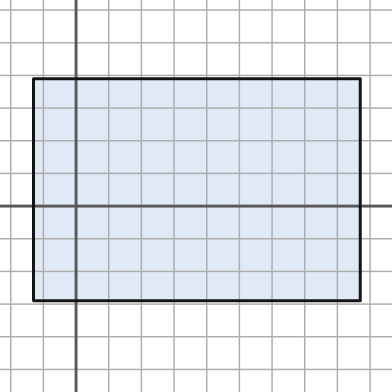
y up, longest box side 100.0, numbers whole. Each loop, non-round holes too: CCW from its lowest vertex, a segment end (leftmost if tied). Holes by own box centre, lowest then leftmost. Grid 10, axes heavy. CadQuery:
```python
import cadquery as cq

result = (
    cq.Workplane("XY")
    .moveTo(-13.0, -29.0)
    .lineTo(87.0, -29.0)
    .lineTo(87.0, 39.0)
    .lineTo(-13.0, 39.0)
    .close()
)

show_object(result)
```